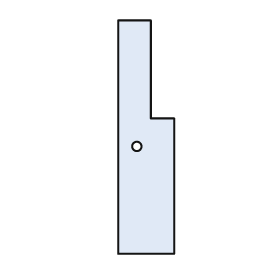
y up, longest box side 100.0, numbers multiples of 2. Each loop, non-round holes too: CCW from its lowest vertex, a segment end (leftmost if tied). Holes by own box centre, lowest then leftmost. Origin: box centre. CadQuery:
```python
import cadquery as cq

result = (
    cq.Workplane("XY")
    .moveTo(-12.0, -50.0)
    .lineTo(12.0, -50.0)
    .lineTo(12.0, 8.0)
    .lineTo(2.0, 8.0)
    .lineTo(2.0, 50.0)
    .lineTo(-12.0, 50.0)
    .close()
    .moveTo(-4.0, -4.0)
    .circle(2.0)
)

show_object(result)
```